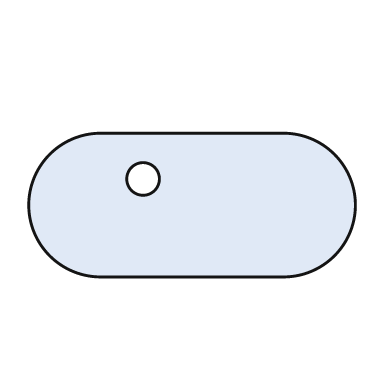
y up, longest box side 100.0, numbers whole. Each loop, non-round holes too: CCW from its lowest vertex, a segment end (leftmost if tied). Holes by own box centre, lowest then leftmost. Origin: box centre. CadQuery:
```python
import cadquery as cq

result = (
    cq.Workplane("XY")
    .moveTo(-28.0, -22.0)
    .lineTo(28.0, -22.0)
    .threePointArc((50.0, 0.0), (28.0, 22.0))
    .lineTo(-28.0, 22.0)
    .threePointArc((-50.0, 0.0), (-28.0, -22.0))
    .close()
    .moveTo(-15.0, 8.0)
    .circle(5.0)
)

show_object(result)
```